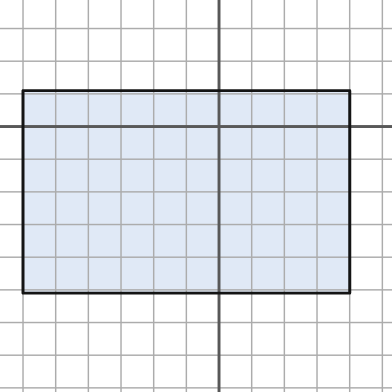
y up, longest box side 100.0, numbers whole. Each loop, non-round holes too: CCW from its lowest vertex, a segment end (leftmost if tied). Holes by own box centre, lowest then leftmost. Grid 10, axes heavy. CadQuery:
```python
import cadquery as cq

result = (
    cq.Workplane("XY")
    .moveTo(-60.0, -51.0)
    .lineTo(40.0, -51.0)
    .lineTo(40.0, 11.0)
    .lineTo(-60.0, 11.0)
    .close()
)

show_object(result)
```